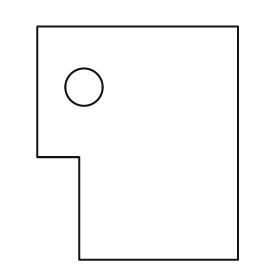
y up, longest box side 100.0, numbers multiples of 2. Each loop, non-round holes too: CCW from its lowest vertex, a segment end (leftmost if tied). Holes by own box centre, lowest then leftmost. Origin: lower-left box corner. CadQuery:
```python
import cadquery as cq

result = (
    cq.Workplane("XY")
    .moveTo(18.0, 0.0)
    .lineTo(86.0, 0.0)
    .lineTo(86.0, 100.0)
    .lineTo(0.0, 100.0)
    .lineTo(0.0, 44.0)
    .lineTo(18.0, 44.0)
    .close()
    .moveTo(20.0, 74.0)
    .circle(8.0)
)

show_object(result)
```